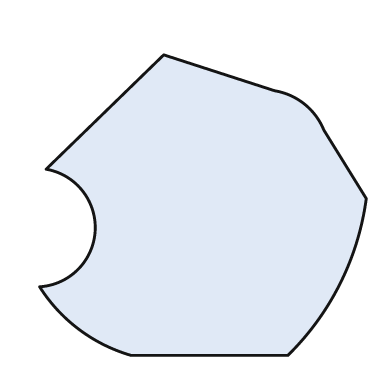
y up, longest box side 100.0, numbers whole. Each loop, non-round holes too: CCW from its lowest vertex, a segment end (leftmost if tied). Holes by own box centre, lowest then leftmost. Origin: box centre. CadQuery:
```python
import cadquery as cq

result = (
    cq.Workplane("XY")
    .moveTo(-22.0, -46.0)
    .lineTo(26.0, -46.0)
    .threePointArc((42.0, -24.0), (50.0, 2.0))
    .lineTo(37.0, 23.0)
    .threePointArc((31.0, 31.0), (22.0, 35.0))
    .lineTo(-12.0, 46.0)
    .lineTo(-48.0, 11.0)
    .threePointArc((-33.0, -8.0), (-50.0, -25.0))
    .threePointArc((-38.0, -38.0), (-22.0, -46.0))
    .close()
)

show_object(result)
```